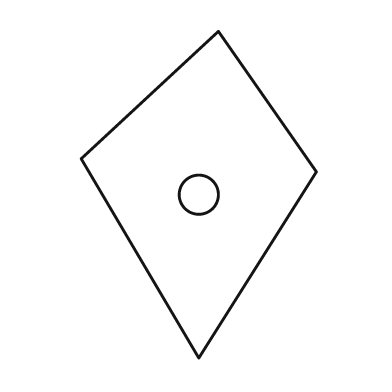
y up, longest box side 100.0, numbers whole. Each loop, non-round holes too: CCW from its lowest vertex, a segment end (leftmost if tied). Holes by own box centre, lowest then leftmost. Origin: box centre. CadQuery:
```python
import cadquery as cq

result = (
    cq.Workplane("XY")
    .moveTo(0.0, -50.0)
    .lineTo(36.0, 7.0)
    .lineTo(6.0, 50.0)
    .lineTo(-36.0, 11.0)
    .close()
    .moveTo(0.0, 0.0)
    .circle(6.0)
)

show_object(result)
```